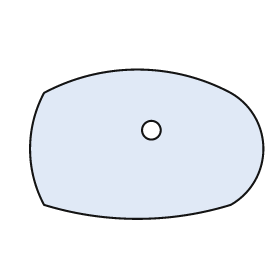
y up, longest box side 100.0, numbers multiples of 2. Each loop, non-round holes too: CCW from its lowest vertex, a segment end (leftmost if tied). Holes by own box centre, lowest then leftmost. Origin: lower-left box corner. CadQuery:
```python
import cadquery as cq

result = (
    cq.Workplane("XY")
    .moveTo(6.0, 6.0)
    .threePointArc((46.0, 0.0), (86.0, 6.0))
    .threePointArc((100.0, 30.0), (86.0, 54.0))
    .threePointArc((46.0, 64.0), (6.0, 54.0))
    .threePointArc((0.0, 30.0), (6.0, 6.0))
    .close()
    .moveTo(52.0, 38.0)
    .circle(4.0)
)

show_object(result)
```